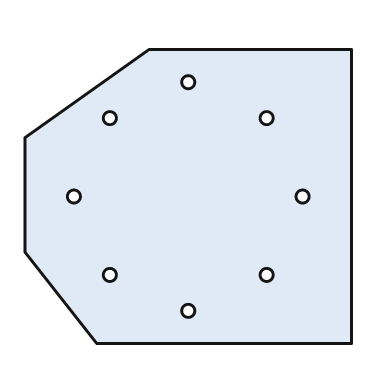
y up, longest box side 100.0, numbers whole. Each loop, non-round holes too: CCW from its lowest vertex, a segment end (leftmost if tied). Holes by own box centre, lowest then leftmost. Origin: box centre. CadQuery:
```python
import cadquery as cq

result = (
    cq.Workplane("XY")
    .moveTo(-28.0, -45.0)
    .lineTo(50.0, -45.0)
    .lineTo(50.0, 45.0)
    .lineTo(-12.0, 45.0)
    .lineTo(-50.0, 18.0)
    .lineTo(-50.0, -17.0)
    .close()
    .moveTo(0.0, -35.0)
    .circle(2.0)
    .moveTo(-24.0, -24.0)
    .circle(2.0)
    .moveTo(24.0, -24.0)
    .circle(2.0)
    .moveTo(-35.0, 0.0)
    .circle(2.0)
    .moveTo(35.0, 0.0)
    .circle(2.0)
    .moveTo(-24.0, 24.0)
    .circle(2.0)
    .moveTo(24.0, 24.0)
    .circle(2.0)
    .moveTo(0.0, 35.0)
    .circle(2.0)
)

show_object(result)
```